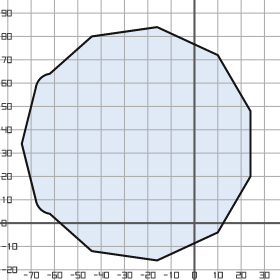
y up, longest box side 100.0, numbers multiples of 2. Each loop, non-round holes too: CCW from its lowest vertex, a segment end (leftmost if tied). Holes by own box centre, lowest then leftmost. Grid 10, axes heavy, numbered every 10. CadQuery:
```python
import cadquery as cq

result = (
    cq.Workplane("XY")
    .moveTo(-16.0, -16.0)
    .lineTo(10.0, -4.0)
    .lineTo(24.0, 20.0)
    .lineTo(24.0, 48.0)
    .lineTo(10.0, 72.0)
    .lineTo(-16.0, 84.0)
    .lineTo(-44.0, 80.0)
    .lineTo(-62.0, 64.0)
    .threePointArc((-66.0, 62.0), (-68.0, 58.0))
    .lineTo(-74.0, 34.0)
    .lineTo(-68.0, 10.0)
    .threePointArc((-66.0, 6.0), (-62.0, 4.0))
    .lineTo(-44.0, -12.0)
    .close()
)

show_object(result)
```